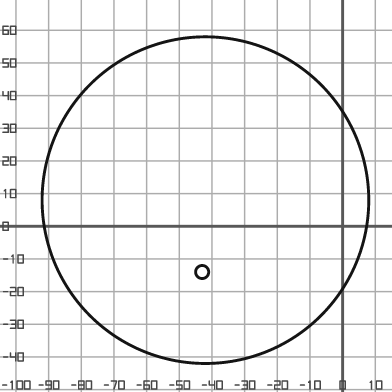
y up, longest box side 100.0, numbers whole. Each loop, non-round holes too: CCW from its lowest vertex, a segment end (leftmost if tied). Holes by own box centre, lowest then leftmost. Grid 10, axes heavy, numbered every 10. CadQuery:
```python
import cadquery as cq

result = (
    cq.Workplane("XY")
    .moveTo(-42.0, 8.0)
    .circle(50.0)
    .moveTo(-43.0, -14.0)
    .circle(2.0)
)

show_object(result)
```